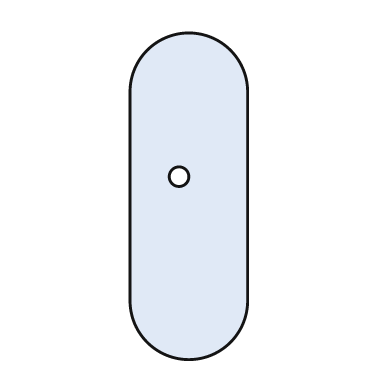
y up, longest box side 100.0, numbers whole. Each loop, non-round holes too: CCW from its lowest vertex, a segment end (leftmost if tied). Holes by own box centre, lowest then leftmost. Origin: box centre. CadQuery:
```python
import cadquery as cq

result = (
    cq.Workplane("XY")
    .moveTo(-18.0, -32.0)
    .threePointArc((0.0, -50.0), (18.0, -32.0))
    .lineTo(18.0, 32.0)
    .threePointArc((0.0, 50.0), (-18.0, 32.0))
    .close()
    .moveTo(-3.0, 6.0)
    .circle(3.0)
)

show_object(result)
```